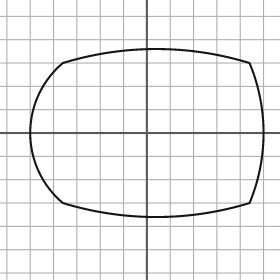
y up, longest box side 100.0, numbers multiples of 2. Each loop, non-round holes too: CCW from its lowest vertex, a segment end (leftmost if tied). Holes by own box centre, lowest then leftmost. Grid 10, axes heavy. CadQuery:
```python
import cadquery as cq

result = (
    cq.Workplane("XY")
    .moveTo(-36.0, -30.0)
    .threePointArc((4.0, -36.0), (44.0, -30.0))
    .threePointArc((50.0, 0.0), (44.0, 30.0))
    .threePointArc((4.0, 36.0), (-36.0, 30.0))
    .threePointArc((-50.0, 0.0), (-36.0, -30.0))
    .close()
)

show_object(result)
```